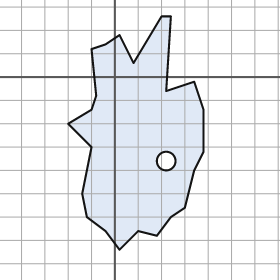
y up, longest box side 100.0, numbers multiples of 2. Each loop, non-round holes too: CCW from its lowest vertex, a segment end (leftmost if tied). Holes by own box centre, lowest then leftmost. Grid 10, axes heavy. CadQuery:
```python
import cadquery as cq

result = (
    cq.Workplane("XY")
    .moveTo(2.0, -74.0)
    .lineTo(10.0, -66.0)
    .lineTo(18.0, -68.0)
    .lineTo(24.0, -60.0)
    .lineTo(30.0, -56.0)
    .lineTo(34.0, -40.0)
    .lineTo(38.0, -32.0)
    .lineTo(38.0, -14.0)
    .lineTo(34.0, -2.0)
    .lineTo(22.0, -6.0)
    .lineTo(24.0, 26.0)
    .lineTo(20.0, 26.0)
    .lineTo(8.0, 6.0)
    .lineTo(2.0, 18.0)
    .lineTo(-4.0, 14.0)
    .lineTo(-10.0, 12.0)
    .lineTo(-8.0, -8.0)
    .lineTo(-10.0, -14.0)
    .lineTo(-20.0, -20.0)
    .lineTo(-10.0, -30.0)
    .lineTo(-14.0, -50.0)
    .lineTo(-12.0, -60.0)
    .lineTo(-4.0, -66.0)
    .close()
    .moveTo(22.0, -36.0)
    .circle(4.0)
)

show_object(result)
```